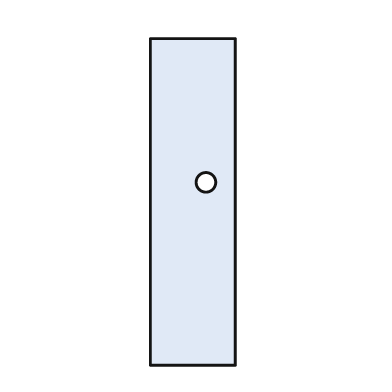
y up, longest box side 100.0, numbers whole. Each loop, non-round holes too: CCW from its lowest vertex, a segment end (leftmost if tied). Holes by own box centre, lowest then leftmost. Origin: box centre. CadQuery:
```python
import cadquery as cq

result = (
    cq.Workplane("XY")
    .moveTo(-13.0, -50.0)
    .lineTo(13.0, -50.0)
    .lineTo(13.0, 50.0)
    .lineTo(-13.0, 50.0)
    .close()
    .moveTo(4.0, 6.0)
    .circle(3.0)
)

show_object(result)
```